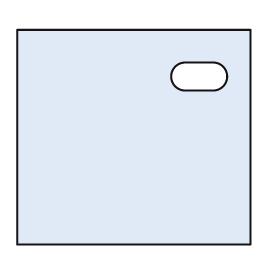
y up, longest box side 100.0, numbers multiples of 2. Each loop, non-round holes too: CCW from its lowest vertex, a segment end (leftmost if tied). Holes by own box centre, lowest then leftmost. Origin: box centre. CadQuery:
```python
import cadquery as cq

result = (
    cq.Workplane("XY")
    .moveTo(-50.0, -46.0)
    .lineTo(50.0, -46.0)
    .lineTo(50.0, 46.0)
    .lineTo(-50.0, 46.0)
    .close()
    .moveTo(22.0, 20.0)
    .lineTo(34.0, 20.0)
    .threePointArc((40.0, 26.0), (34.0, 32.0))
    .lineTo(22.0, 32.0)
    .threePointArc((16.0, 26.0), (22.0, 20.0))
    .close()
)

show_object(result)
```